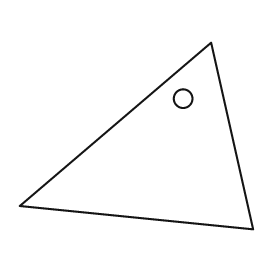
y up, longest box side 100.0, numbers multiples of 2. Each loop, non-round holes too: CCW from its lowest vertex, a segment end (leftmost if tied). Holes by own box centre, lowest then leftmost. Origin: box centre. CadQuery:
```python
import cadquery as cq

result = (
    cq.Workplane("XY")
    .moveTo(50.0, -40.0)
    .lineTo(32.0, 40.0)
    .lineTo(-50.0, -30.0)
    .close()
    .moveTo(20.0, 16.0)
    .circle(4.0)
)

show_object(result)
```